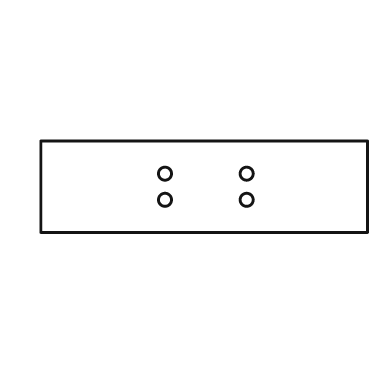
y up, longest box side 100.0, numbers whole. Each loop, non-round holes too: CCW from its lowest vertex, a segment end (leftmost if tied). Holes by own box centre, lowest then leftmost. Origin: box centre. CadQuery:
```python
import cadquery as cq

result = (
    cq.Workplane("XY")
    .moveTo(-50.0, -14.0)
    .lineTo(50.0, -14.0)
    .lineTo(50.0, 14.0)
    .lineTo(-50.0, 14.0)
    .close()
    .moveTo(-12.0, -4.0)
    .circle(2.0)
    .moveTo(13.0, -4.0)
    .circle(2.0)
    .moveTo(-12.0, 4.0)
    .circle(2.0)
    .moveTo(13.0, 4.0)
    .circle(2.0)
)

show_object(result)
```